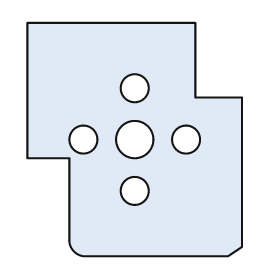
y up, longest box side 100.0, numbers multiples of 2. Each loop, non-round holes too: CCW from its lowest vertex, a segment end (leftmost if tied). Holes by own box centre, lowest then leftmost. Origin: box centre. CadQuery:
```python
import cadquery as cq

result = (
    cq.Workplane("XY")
    .moveTo(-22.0, -50.0)
    .lineTo(40.0, -50.0)
    .lineTo(46.0, -46.0)
    .lineTo(46.0, 18.0)
    .lineTo(26.0, 18.0)
    .lineTo(26.0, 50.0)
    .lineTo(-46.0, 50.0)
    .lineTo(-46.0, -8.0)
    .lineTo(-28.0, -8.0)
    .lineTo(-28.0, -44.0)
    .threePointArc((-26.0, -48.0), (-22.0, -50.0))
    .close()
    .moveTo(0.0, -22.0)
    .circle(6.0)
    .moveTo(-22.0, 0.0)
    .circle(6.0)
    .moveTo(0.0, 0.0)
    .circle(8.0)
    .moveTo(22.0, 0.0)
    .circle(6.0)
    .moveTo(0.0, 22.0)
    .circle(6.0)
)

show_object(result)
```